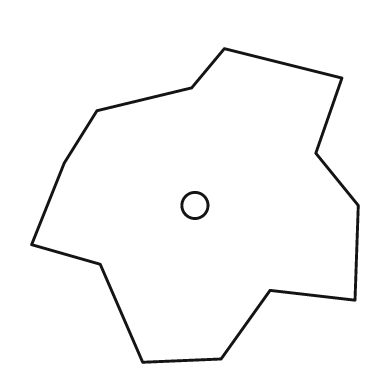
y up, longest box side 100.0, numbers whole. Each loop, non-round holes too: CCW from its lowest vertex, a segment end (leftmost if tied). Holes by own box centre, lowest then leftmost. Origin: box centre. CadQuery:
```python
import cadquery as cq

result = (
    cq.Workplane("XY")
    .moveTo(-16.0, -48.0)
    .lineTo(8.0, -47.0)
    .lineTo(23.0, -26.0)
    .lineTo(49.0, -29.0)
    .lineTo(50.0, 0.0)
    .lineTo(37.0, 16.0)
    .lineTo(45.0, 39.0)
    .lineTo(9.0, 48.0)
    .lineTo(-1.0, 36.0)
    .lineTo(-30.0, 29.0)
    .lineTo(-40.0, 13.0)
    .lineTo(-50.0, -12.0)
    .lineTo(-29.0, -18.0)
    .close()
    .moveTo(0.0, 0.0)
    .circle(4.0)
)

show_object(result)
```